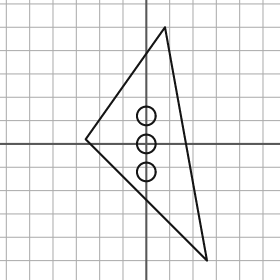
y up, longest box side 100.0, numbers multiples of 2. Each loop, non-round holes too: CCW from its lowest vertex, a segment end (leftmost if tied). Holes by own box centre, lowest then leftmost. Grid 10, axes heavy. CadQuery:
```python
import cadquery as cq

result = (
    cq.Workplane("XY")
    .moveTo(26.0, -50.0)
    .lineTo(8.0, 50.0)
    .lineTo(-26.0, 2.0)
    .close()
    .moveTo(0.0, -12.0)
    .circle(4.0)
    .moveTo(0.0, 0.0)
    .circle(4.0)
    .moveTo(0.0, 12.0)
    .circle(4.0)
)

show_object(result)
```